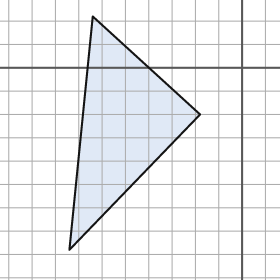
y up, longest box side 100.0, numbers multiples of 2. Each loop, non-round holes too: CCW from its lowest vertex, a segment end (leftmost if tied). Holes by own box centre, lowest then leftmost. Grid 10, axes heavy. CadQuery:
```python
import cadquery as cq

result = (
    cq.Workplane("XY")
    .moveTo(-74.0, -78.0)
    .lineTo(-18.0, -20.0)
    .lineTo(-64.0, 22.0)
    .close()
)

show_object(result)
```